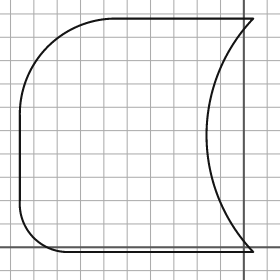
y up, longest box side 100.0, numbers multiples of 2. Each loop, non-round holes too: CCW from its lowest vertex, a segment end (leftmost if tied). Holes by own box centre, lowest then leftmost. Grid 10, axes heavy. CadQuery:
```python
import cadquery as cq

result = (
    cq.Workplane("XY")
    .moveTo(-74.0, -2.0)
    .lineTo(4.0, -2.0)
    .threePointArc((-16.0, 48.0), (4.0, 98.0))
    .lineTo(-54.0, 98.0)
    .threePointArc((-84.0, 86.0), (-96.0, 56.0))
    .lineTo(-96.0, 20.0)
    .threePointArc((-90.0, 4.0), (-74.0, -2.0))
    .close()
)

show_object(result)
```